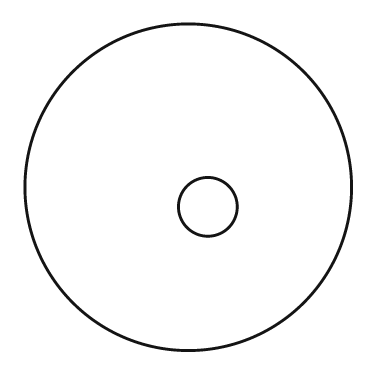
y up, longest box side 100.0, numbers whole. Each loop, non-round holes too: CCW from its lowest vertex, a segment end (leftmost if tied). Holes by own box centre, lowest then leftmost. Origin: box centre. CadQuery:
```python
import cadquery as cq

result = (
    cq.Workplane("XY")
    .moveTo(0.0, 0.0)
    .circle(50.0)
    .moveTo(6.0, -6.0)
    .circle(9.0)
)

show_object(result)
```